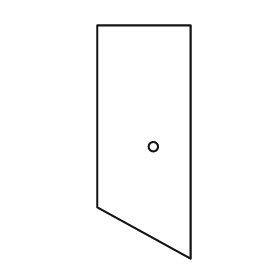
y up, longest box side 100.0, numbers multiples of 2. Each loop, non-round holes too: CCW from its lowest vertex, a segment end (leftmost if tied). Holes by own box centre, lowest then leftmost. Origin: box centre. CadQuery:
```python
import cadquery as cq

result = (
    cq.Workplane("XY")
    .moveTo(20.0, -50.0)
    .lineTo(20.0, 50.0)
    .lineTo(-20.0, 50.0)
    .lineTo(-20.0, -28.0)
    .close()
    .moveTo(4.0, -2.0)
    .circle(2.0)
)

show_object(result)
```